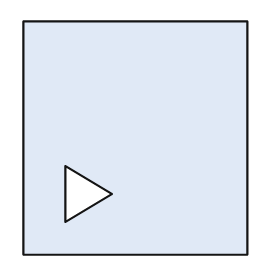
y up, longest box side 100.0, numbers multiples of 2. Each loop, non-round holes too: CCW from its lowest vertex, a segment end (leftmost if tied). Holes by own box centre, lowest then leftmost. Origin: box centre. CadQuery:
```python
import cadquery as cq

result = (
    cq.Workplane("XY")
    .moveTo(-48.0, -50.0)
    .lineTo(48.0, -50.0)
    .lineTo(48.0, 50.0)
    .lineTo(-48.0, 50.0)
    .close()
    .moveTo(-30.0, -36.0)
    .lineTo(-10.0, -24.0)
    .lineTo(-30.0, -12.0)
    .close()
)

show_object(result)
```